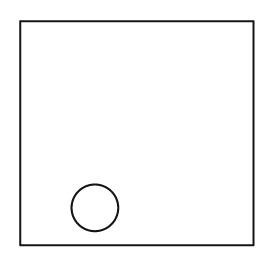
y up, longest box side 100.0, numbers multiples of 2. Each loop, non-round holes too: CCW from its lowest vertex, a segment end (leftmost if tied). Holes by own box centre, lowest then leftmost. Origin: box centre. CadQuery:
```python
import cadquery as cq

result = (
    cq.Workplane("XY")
    .moveTo(-50.0, -48.0)
    .lineTo(50.0, -48.0)
    .lineTo(50.0, 48.0)
    .lineTo(-50.0, 48.0)
    .close()
    .moveTo(-18.0, -32.0)
    .circle(10.0)
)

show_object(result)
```